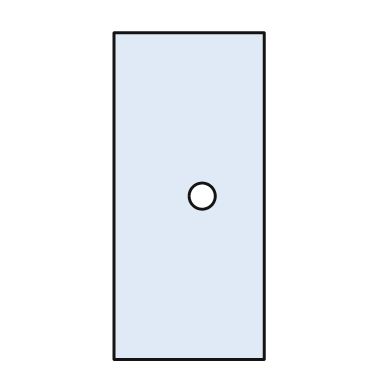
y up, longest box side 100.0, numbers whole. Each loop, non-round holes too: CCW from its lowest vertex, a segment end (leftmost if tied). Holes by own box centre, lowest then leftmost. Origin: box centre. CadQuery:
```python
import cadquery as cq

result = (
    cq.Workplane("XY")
    .moveTo(-23.0, -50.0)
    .lineTo(23.0, -50.0)
    .lineTo(23.0, 50.0)
    .lineTo(-23.0, 50.0)
    .close()
    .moveTo(4.0, 0.0)
    .circle(4.0)
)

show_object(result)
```